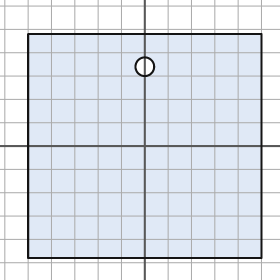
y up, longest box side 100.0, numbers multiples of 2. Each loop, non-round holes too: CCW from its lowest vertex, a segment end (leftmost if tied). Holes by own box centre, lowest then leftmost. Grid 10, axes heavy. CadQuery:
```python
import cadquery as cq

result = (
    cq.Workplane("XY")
    .moveTo(-50.0, -48.0)
    .lineTo(50.0, -48.0)
    .lineTo(50.0, 48.0)
    .lineTo(-50.0, 48.0)
    .close()
    .moveTo(0.0, 34.0)
    .circle(4.0)
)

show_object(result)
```